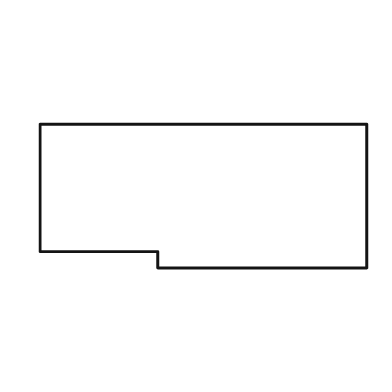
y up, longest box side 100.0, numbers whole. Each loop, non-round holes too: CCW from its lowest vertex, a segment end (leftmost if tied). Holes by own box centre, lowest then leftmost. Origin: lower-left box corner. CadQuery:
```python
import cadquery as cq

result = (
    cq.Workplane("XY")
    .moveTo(36.0, 0.0)
    .lineTo(100.0, 0.0)
    .lineTo(100.0, 44.0)
    .lineTo(0.0, 44.0)
    .lineTo(0.0, 5.0)
    .lineTo(36.0, 5.0)
    .close()
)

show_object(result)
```